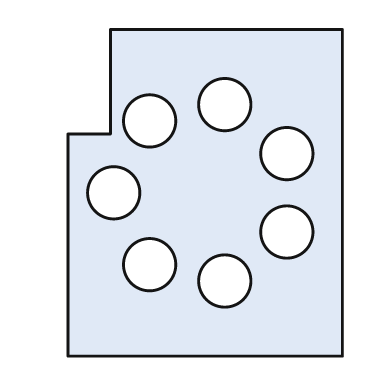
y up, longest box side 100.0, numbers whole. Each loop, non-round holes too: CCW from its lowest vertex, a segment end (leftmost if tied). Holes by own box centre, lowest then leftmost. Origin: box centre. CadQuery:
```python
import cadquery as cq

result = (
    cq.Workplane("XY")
    .moveTo(-42.0, -50.0)
    .lineTo(42.0, -50.0)
    .lineTo(42.0, 50.0)
    .lineTo(-29.0, 50.0)
    .lineTo(-29.0, 18.0)
    .lineTo(-42.0, 18.0)
    .close()
    .moveTo(6.0, -27.0)
    .circle(8.0)
    .moveTo(-17.0, -22.0)
    .circle(8.0)
    .moveTo(25.0, -12.0)
    .circle(8.0)
    .moveTo(-28.0, 0.0)
    .circle(8.0)
    .moveTo(25.0, 12.0)
    .circle(8.0)
    .moveTo(-17.0, 22.0)
    .circle(8.0)
    .moveTo(6.0, 27.0)
    .circle(8.0)
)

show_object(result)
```